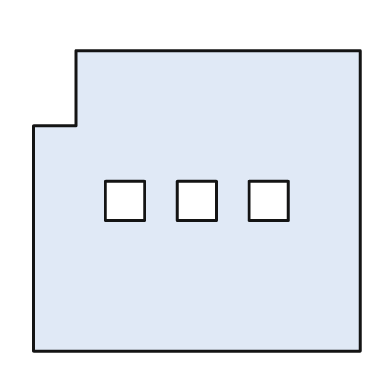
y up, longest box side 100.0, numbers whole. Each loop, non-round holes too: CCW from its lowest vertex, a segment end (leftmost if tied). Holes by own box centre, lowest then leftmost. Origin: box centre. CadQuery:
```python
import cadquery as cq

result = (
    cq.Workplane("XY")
    .moveTo(-50.0, -46.0)
    .lineTo(50.0, -46.0)
    .lineTo(50.0, 46.0)
    .lineTo(-37.0, 46.0)
    .lineTo(-37.0, 23.0)
    .lineTo(-50.0, 23.0)
    .close()
    .moveTo(-28.0, -6.0)
    .lineTo(-16.0, -6.0)
    .lineTo(-16.0, 6.0)
    .lineTo(-28.0, 6.0)
    .close()
    .moveTo(-6.0, -6.0)
    .lineTo(6.0, -6.0)
    .lineTo(6.0, 6.0)
    .lineTo(-6.0, 6.0)
    .close()
    .moveTo(16.0, -6.0)
    .lineTo(28.0, -6.0)
    .lineTo(28.0, 6.0)
    .lineTo(16.0, 6.0)
    .close()
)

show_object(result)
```